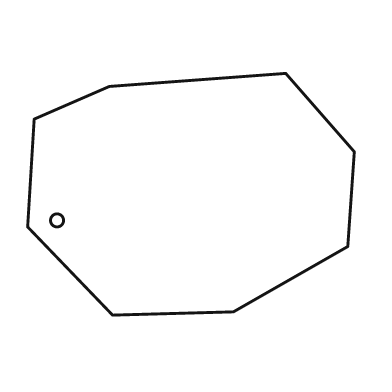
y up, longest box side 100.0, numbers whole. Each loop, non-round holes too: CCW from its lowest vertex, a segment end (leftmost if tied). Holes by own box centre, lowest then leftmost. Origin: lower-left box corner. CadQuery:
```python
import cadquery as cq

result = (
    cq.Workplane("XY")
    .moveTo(26.0, 0.0)
    .lineTo(63.0, 1.0)
    .lineTo(98.0, 21.0)
    .lineTo(100.0, 50.0)
    .lineTo(79.0, 74.0)
    .lineTo(25.0, 70.0)
    .lineTo(2.0, 60.0)
    .lineTo(0.0, 27.0)
    .close()
    .moveTo(9.0, 29.0)
    .circle(2.0)
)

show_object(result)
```